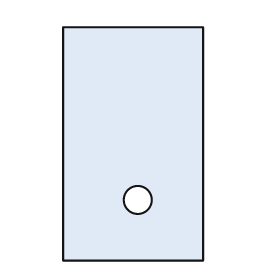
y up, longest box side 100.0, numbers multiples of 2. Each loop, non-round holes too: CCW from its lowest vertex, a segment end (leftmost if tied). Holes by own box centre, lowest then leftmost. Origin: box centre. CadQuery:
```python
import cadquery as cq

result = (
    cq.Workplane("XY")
    .moveTo(-30.0, -50.0)
    .lineTo(30.0, -50.0)
    .lineTo(30.0, 50.0)
    .lineTo(-30.0, 50.0)
    .close()
    .moveTo(2.0, -24.0)
    .circle(6.0)
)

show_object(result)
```